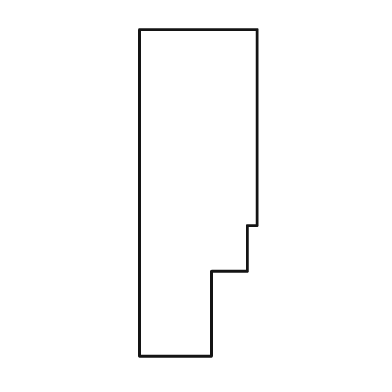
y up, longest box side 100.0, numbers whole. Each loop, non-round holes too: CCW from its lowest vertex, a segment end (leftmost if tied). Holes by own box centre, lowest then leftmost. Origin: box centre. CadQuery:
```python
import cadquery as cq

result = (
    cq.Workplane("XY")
    .moveTo(-18.0, -50.0)
    .lineTo(4.0, -50.0)
    .lineTo(4.0, -24.0)
    .lineTo(15.0, -24.0)
    .lineTo(15.0, -10.0)
    .lineTo(18.0, -10.0)
    .lineTo(18.0, 50.0)
    .lineTo(-18.0, 50.0)
    .close()
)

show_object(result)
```